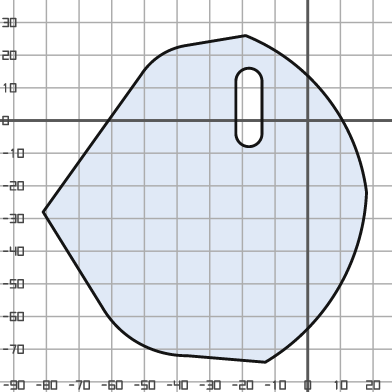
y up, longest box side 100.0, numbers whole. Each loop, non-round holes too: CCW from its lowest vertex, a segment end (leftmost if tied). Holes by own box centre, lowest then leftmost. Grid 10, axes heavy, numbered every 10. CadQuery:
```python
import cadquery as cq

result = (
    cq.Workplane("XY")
    .moveTo(-13.0, -74.0)
    .threePointArc((9.0, -52.0), (18.0, -22.0))
    .threePointArc((6.0, 7.0), (-19.0, 26.0))
    .lineTo(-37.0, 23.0)
    .threePointArc((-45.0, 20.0), (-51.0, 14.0))
    .lineTo(-81.0, -28.0)
    .lineTo(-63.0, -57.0)
    .threePointArc((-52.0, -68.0), (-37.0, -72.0))
    .close()
    .moveTo(-22.0, -4.0)
    .threePointArc((-18.0, -8.0), (-14.0, -4.0))
    .lineTo(-14.0, 12.0)
    .threePointArc((-18.0, 16.0), (-22.0, 12.0))
    .close()
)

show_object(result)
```